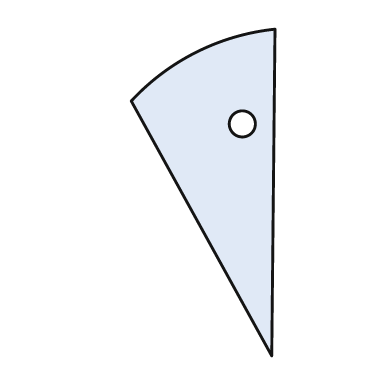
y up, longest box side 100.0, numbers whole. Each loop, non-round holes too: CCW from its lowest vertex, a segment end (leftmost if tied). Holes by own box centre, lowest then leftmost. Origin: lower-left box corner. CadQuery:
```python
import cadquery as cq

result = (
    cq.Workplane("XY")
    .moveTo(43.0, 0.0)
    .lineTo(44.0, 100.0)
    .threePointArc((20.0, 93.0), (0.0, 78.0))
    .close()
    .moveTo(34.0, 71.0)
    .circle(4.0)
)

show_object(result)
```